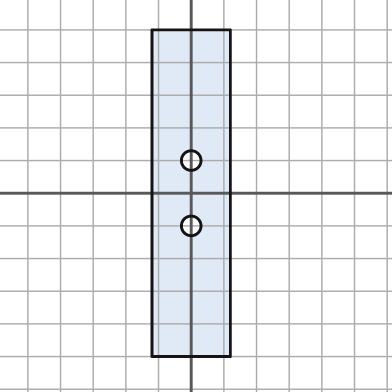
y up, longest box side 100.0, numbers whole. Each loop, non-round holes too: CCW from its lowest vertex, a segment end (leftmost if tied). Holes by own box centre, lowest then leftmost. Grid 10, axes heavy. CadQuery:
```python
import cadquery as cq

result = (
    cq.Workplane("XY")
    .moveTo(-12.0, -50.0)
    .lineTo(12.0, -50.0)
    .lineTo(12.0, 50.0)
    .lineTo(-12.0, 50.0)
    .close()
    .moveTo(0.0, -10.0)
    .circle(3.0)
    .moveTo(0.0, 10.0)
    .circle(3.0)
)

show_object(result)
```